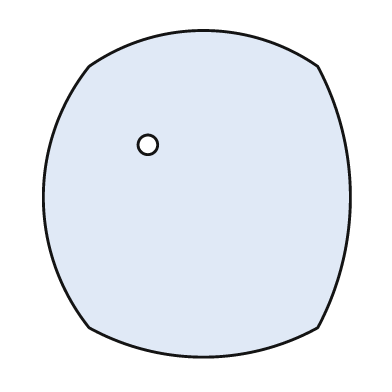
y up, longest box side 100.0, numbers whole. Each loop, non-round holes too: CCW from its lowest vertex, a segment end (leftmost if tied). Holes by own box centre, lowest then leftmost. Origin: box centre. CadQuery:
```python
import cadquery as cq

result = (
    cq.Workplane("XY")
    .moveTo(-33.0, -41.0)
    .threePointArc((2.0, -50.0), (37.0, -41.0))
    .threePointArc((47.0, -1.0), (37.0, 39.0))
    .threePointArc((2.0, 50.0), (-33.0, 39.0))
    .threePointArc((-47.0, -1.0), (-33.0, -41.0))
    .close()
    .moveTo(-15.0, 15.0)
    .circle(3.0)
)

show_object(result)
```